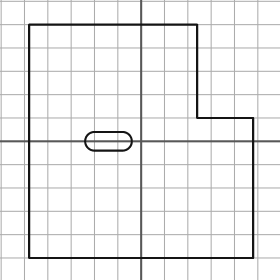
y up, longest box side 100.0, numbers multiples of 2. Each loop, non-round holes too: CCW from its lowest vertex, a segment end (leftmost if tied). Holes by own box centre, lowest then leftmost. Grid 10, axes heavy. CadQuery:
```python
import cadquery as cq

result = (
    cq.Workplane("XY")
    .moveTo(-48.0, -50.0)
    .lineTo(48.0, -50.0)
    .lineTo(48.0, 10.0)
    .lineTo(24.0, 10.0)
    .lineTo(24.0, 50.0)
    .lineTo(-48.0, 50.0)
    .close()
    .moveTo(-20.0, -4.0)
    .lineTo(-8.0, -4.0)
    .threePointArc((-4.0, 0.0), (-8.0, 4.0))
    .lineTo(-20.0, 4.0)
    .threePointArc((-24.0, 0.0), (-20.0, -4.0))
    .close()
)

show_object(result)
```